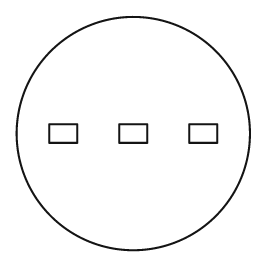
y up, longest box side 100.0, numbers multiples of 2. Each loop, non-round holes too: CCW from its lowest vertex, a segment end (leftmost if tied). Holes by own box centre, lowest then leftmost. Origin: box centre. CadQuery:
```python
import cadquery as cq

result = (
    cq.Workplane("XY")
    .moveTo(0.0, 0.0)
    .circle(50.0)
    .moveTo(-36.0, -4.0)
    .lineTo(-24.0, -4.0)
    .lineTo(-24.0, 4.0)
    .lineTo(-36.0, 4.0)
    .close()
    .moveTo(-6.0, -4.0)
    .lineTo(6.0, -4.0)
    .lineTo(6.0, 4.0)
    .lineTo(-6.0, 4.0)
    .close()
    .moveTo(24.0, -4.0)
    .lineTo(36.0, -4.0)
    .lineTo(36.0, 4.0)
    .lineTo(24.0, 4.0)
    .close()
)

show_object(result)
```